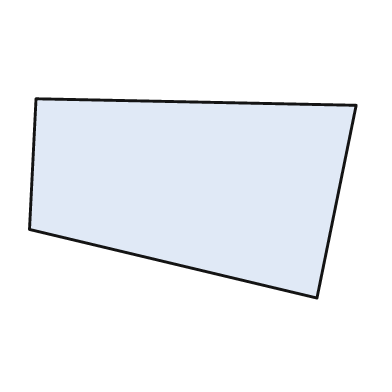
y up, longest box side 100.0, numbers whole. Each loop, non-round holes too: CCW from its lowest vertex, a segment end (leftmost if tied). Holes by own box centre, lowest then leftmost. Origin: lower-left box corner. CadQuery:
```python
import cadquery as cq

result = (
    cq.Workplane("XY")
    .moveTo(88.0, 0.0)
    .lineTo(100.0, 59.0)
    .lineTo(2.0, 61.0)
    .lineTo(0.0, 21.0)
    .close()
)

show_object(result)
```